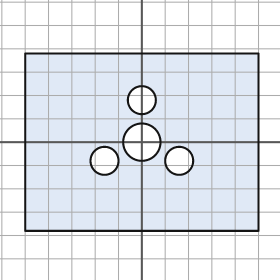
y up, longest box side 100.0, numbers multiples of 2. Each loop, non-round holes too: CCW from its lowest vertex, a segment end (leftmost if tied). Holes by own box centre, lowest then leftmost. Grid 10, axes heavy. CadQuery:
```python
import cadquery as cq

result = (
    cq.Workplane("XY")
    .moveTo(-50.0, -38.0)
    .lineTo(50.0, -38.0)
    .lineTo(50.0, 38.0)
    .lineTo(-50.0, 38.0)
    .close()
    .moveTo(-16.0, -8.0)
    .circle(6.0)
    .moveTo(16.0, -8.0)
    .circle(6.0)
    .moveTo(0.0, 0.0)
    .circle(8.0)
    .moveTo(0.0, 18.0)
    .circle(6.0)
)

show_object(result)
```